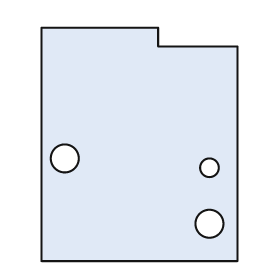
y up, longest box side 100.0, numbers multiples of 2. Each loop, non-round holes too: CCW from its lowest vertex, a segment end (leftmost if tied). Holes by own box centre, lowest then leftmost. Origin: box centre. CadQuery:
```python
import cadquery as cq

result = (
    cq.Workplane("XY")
    .moveTo(-42.0, -50.0)
    .lineTo(42.0, -50.0)
    .lineTo(42.0, 42.0)
    .lineTo(8.0, 42.0)
    .lineTo(8.0, 50.0)
    .lineTo(-42.0, 50.0)
    .close()
    .moveTo(30.0, -34.0)
    .circle(6.0)
    .moveTo(30.0, -10.0)
    .circle(4.0)
    .moveTo(-32.0, -6.0)
    .circle(6.0)
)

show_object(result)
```